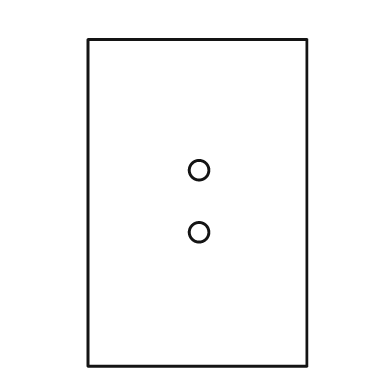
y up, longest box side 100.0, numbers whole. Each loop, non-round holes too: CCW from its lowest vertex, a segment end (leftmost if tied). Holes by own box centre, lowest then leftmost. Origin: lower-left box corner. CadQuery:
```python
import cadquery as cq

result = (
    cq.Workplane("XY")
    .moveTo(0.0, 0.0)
    .lineTo(67.0, 0.0)
    .lineTo(67.0, 100.0)
    .lineTo(0.0, 100.0)
    .close()
    .moveTo(34.0, 41.0)
    .circle(3.0)
    .moveTo(34.0, 60.0)
    .circle(3.0)
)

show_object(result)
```